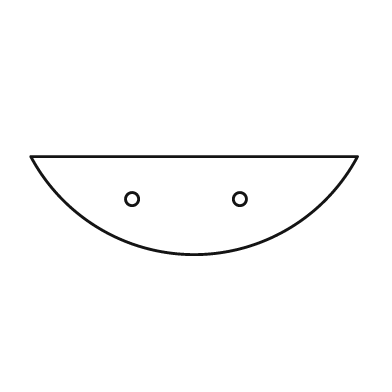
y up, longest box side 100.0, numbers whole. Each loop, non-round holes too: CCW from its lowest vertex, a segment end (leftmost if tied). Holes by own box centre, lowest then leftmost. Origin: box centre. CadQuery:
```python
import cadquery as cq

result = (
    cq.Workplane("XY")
    .moveTo(-50.0, 15.0)
    .threePointArc((0.0, -15.0), (50.0, 15.0))
    .close()
    .moveTo(-19.0, 2.0)
    .circle(2.0)
    .moveTo(14.0, 2.0)
    .circle(2.0)
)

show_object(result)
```